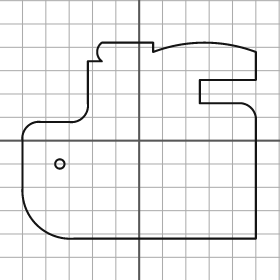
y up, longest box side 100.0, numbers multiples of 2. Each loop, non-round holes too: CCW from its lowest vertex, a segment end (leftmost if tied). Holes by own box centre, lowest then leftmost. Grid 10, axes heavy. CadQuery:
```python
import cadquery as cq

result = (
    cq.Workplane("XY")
    .moveTo(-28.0, -42.0)
    .lineTo(50.0, -42.0)
    .lineTo(50.0, 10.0)
    .threePointArc((48.0, 14.0), (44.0, 16.0))
    .lineTo(26.0, 16.0)
    .lineTo(26.0, 26.0)
    .lineTo(50.0, 26.0)
    .lineTo(50.0, 38.0)
    .threePointArc((28.0, 42.0), (6.0, 38.0))
    .lineTo(6.0, 42.0)
    .lineTo(-16.0, 42.0)
    .threePointArc((-18.0, 38.0), (-16.0, 34.0))
    .lineTo(-22.0, 34.0)
    .lineTo(-22.0, 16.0)
    .threePointArc((-24.0, 10.0), (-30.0, 8.0))
    .lineTo(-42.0, 8.0)
    .threePointArc((-48.0, 6.0), (-50.0, 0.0))
    .lineTo(-50.0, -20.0)
    .threePointArc((-44.0, -36.0), (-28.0, -42.0))
    .close()
    .moveTo(-34.0, -10.0)
    .circle(2.0)
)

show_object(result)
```